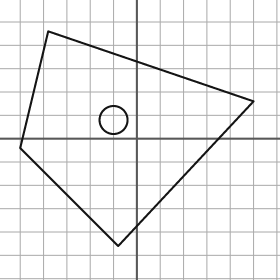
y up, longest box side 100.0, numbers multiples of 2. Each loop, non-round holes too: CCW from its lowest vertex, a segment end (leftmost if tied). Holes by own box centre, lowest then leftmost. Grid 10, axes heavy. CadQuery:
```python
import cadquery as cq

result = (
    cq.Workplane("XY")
    .moveTo(-8.0, -46.0)
    .lineTo(50.0, 16.0)
    .lineTo(-38.0, 46.0)
    .lineTo(-50.0, -4.0)
    .close()
    .moveTo(-10.0, 8.0)
    .circle(6.0)
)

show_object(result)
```